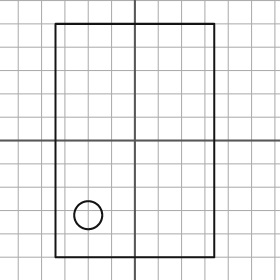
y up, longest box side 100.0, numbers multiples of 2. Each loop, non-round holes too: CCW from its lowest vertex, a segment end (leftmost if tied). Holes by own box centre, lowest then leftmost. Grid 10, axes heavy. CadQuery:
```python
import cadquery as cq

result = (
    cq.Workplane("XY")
    .moveTo(-34.0, -50.0)
    .lineTo(34.0, -50.0)
    .lineTo(34.0, 50.0)
    .lineTo(-34.0, 50.0)
    .close()
    .moveTo(-20.0, -32.0)
    .circle(6.0)
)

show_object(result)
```